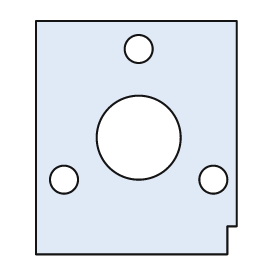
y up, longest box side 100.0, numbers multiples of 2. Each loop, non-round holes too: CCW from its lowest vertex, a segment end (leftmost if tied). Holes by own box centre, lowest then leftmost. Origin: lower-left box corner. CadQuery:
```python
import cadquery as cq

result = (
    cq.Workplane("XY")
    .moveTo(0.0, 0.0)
    .lineTo(82.0, 0.0)
    .lineTo(82.0, 12.0)
    .lineTo(86.0, 12.0)
    .lineTo(86.0, 100.0)
    .lineTo(0.0, 100.0)
    .close()
    .moveTo(12.0, 32.0)
    .circle(6.0)
    .moveTo(76.0, 32.0)
    .circle(6.0)
    .moveTo(44.0, 50.0)
    .circle(18.0)
    .moveTo(44.0, 88.0)
    .circle(6.0)
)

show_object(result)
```